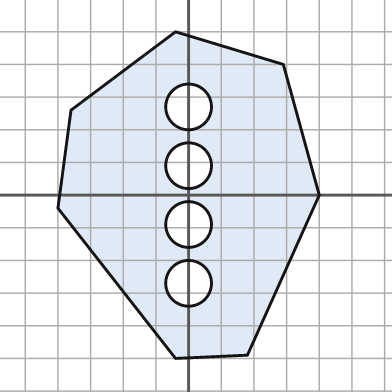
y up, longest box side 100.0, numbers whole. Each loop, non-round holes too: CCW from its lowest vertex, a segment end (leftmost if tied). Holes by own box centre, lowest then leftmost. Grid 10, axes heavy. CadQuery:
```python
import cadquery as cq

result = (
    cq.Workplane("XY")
    .moveTo(-4.0, -50.0)
    .lineTo(18.0, -49.0)
    .lineTo(40.0, 0.0)
    .lineTo(29.0, 40.0)
    .lineTo(-4.0, 50.0)
    .lineTo(-36.0, 26.0)
    .lineTo(-40.0, -4.0)
    .close()
    .moveTo(0.0, -27.0)
    .circle(7.0)
    .moveTo(0.0, -9.0)
    .circle(7.0)
    .moveTo(0.0, 9.0)
    .circle(7.0)
    .moveTo(0.0, 27.0)
    .circle(7.0)
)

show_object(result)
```